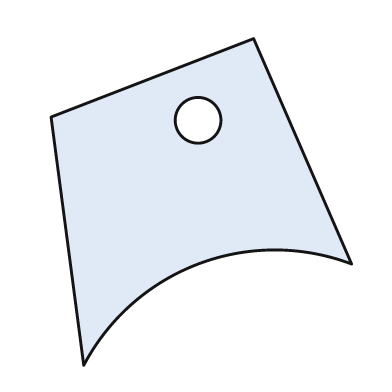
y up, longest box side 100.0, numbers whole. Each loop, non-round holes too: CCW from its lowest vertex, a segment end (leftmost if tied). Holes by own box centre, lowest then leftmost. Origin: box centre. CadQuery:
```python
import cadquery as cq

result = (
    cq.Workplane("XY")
    .moveTo(-36.0, -50.0)
    .threePointArc((-1.0, -19.0), (46.0, -19.0))
    .lineTo(16.0, 50.0)
    .lineTo(-46.0, 26.0)
    .close()
    .moveTo(-1.0, 25.0)
    .circle(7.0)
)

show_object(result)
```